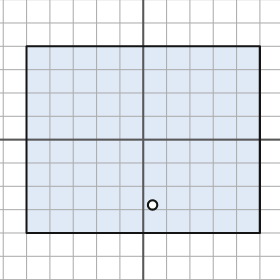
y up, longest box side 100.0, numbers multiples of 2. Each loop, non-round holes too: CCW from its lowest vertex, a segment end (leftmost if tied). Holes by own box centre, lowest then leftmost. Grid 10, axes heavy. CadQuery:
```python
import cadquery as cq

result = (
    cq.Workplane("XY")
    .moveTo(-50.0, -40.0)
    .lineTo(50.0, -40.0)
    .lineTo(50.0, 40.0)
    .lineTo(-50.0, 40.0)
    .close()
    .moveTo(4.0, -28.0)
    .circle(2.0)
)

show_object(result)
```